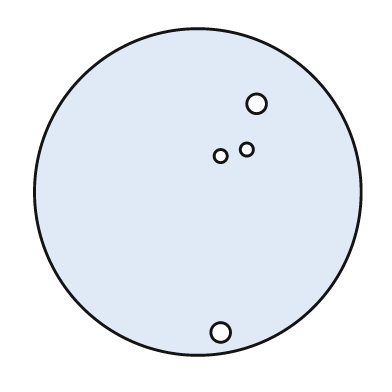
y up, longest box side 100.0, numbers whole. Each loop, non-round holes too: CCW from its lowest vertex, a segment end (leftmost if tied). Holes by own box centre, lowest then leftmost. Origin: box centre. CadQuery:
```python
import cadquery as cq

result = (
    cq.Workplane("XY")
    .moveTo(0.0, 0.0)
    .circle(50.0)
    .moveTo(7.0, -43.0)
    .circle(3.0)
    .moveTo(7.0, 11.0)
    .circle(2.0)
    .moveTo(15.0, 13.0)
    .circle(2.0)
    .moveTo(18.0, 27.0)
    .circle(3.0)
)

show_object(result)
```